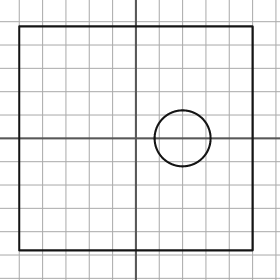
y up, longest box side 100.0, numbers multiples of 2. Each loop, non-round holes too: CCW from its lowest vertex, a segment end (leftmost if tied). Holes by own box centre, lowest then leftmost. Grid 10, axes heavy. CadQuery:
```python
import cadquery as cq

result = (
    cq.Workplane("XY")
    .moveTo(-50.0, -48.0)
    .lineTo(50.0, -48.0)
    .lineTo(50.0, 48.0)
    .lineTo(-50.0, 48.0)
    .close()
    .moveTo(20.0, 0.0)
    .circle(12.0)
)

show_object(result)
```